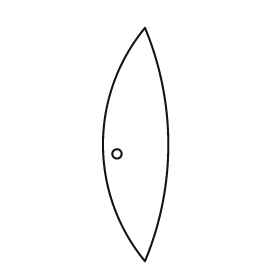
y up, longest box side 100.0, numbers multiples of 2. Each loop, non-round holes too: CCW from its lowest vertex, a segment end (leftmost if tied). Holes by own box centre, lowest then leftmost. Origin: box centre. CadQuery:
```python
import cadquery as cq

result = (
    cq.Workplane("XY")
    .moveTo(4.0, -50.0)
    .threePointArc((14.0, 0.0), (4.0, 50.0))
    .threePointArc((-14.0, 0.0), (4.0, -50.0))
    .close()
    .moveTo(-8.0, -4.0)
    .circle(2.0)
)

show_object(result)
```